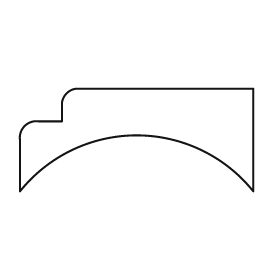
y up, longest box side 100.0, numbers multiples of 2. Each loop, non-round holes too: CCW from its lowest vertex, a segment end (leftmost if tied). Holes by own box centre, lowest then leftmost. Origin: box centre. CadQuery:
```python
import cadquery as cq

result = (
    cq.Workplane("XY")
    .moveTo(-50.0, -22.0)
    .threePointArc((0.0, 2.0), (50.0, -22.0))
    .lineTo(50.0, 22.0)
    .lineTo(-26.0, 22.0)
    .threePointArc((-30.0, 20.0), (-32.0, 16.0))
    .lineTo(-32.0, 8.0)
    .lineTo(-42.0, 8.0)
    .threePointArc((-48.0, 6.0), (-50.0, 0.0))
    .close()
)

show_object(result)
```